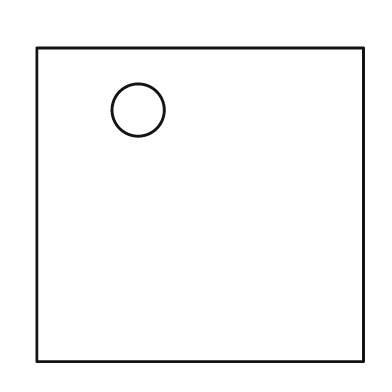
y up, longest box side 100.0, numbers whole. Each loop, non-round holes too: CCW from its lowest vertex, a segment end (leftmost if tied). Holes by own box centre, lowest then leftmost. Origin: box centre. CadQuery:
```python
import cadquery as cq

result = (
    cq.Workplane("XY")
    .moveTo(-50.0, -48.0)
    .lineTo(50.0, -48.0)
    .lineTo(50.0, 48.0)
    .lineTo(-50.0, 48.0)
    .close()
    .moveTo(-19.0, 29.0)
    .circle(8.0)
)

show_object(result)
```